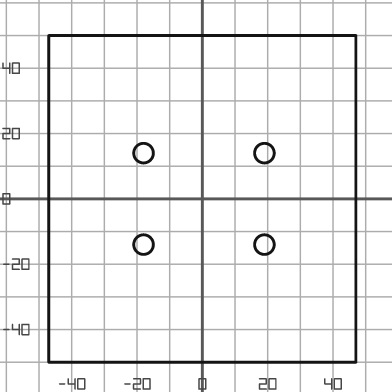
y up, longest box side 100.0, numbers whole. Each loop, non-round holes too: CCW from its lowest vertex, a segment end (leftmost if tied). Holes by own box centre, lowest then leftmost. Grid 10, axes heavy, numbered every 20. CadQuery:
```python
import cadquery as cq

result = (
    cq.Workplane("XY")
    .moveTo(-47.0, -50.0)
    .lineTo(47.0, -50.0)
    .lineTo(47.0, 50.0)
    .lineTo(-47.0, 50.0)
    .close()
    .moveTo(-18.0, -14.0)
    .circle(3.0)
    .moveTo(19.0, -14.0)
    .circle(3.0)
    .moveTo(-18.0, 14.0)
    .circle(3.0)
    .moveTo(19.0, 14.0)
    .circle(3.0)
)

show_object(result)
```